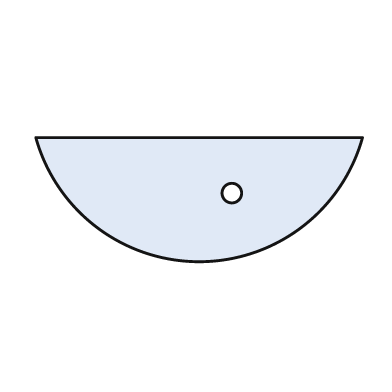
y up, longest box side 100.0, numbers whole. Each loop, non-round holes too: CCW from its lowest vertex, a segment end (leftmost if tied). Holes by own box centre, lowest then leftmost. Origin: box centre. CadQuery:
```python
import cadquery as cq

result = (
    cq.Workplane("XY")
    .moveTo(-50.0, 19.0)
    .threePointArc((0.0, -19.0), (50.0, 19.0))
    .close()
    .moveTo(10.0, 2.0)
    .circle(3.0)
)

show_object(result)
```